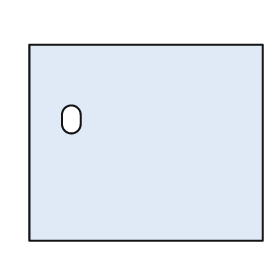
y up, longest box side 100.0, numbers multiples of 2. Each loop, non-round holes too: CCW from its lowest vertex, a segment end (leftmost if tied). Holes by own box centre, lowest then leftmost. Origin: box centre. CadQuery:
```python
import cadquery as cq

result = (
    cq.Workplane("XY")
    .moveTo(-50.0, -42.0)
    .lineTo(50.0, -42.0)
    .lineTo(50.0, 42.0)
    .lineTo(-50.0, 42.0)
    .close()
    .moveTo(-36.0, 8.0)
    .threePointArc((-32.0, 4.0), (-28.0, 8.0))
    .lineTo(-28.0, 12.0)
    .threePointArc((-32.0, 16.0), (-36.0, 12.0))
    .close()
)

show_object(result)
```